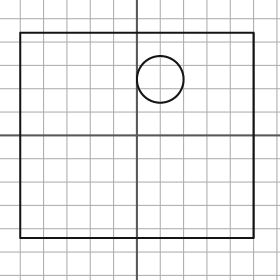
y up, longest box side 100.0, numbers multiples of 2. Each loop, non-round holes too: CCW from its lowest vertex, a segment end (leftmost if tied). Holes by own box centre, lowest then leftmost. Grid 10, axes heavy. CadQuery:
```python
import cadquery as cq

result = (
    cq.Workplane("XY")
    .moveTo(-50.0, -44.0)
    .lineTo(50.0, -44.0)
    .lineTo(50.0, 44.0)
    .lineTo(-50.0, 44.0)
    .close()
    .moveTo(10.0, 24.0)
    .circle(10.0)
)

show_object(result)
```